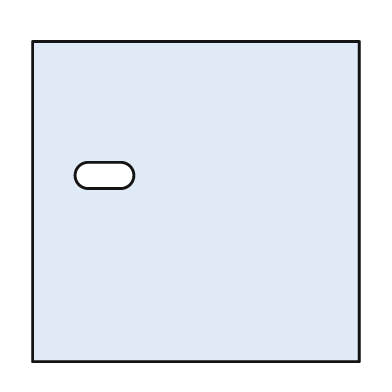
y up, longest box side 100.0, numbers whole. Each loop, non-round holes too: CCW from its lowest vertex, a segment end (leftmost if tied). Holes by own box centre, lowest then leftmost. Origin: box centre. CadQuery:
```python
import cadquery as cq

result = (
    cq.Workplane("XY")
    .moveTo(-50.0, -49.0)
    .lineTo(50.0, -49.0)
    .lineTo(50.0, 49.0)
    .lineTo(-50.0, 49.0)
    .close()
    .moveTo(-33.0, 4.0)
    .lineTo(-23.0, 4.0)
    .threePointArc((-19.0, 8.0), (-23.0, 12.0))
    .lineTo(-33.0, 12.0)
    .threePointArc((-37.0, 8.0), (-33.0, 4.0))
    .close()
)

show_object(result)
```